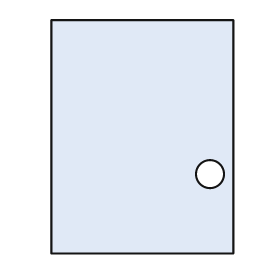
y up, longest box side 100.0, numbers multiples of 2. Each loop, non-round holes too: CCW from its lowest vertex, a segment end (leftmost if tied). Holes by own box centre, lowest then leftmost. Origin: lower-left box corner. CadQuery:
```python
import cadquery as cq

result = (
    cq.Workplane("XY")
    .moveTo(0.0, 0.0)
    .lineTo(78.0, 0.0)
    .lineTo(78.0, 100.0)
    .lineTo(0.0, 100.0)
    .close()
    .moveTo(68.0, 34.0)
    .circle(6.0)
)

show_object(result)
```